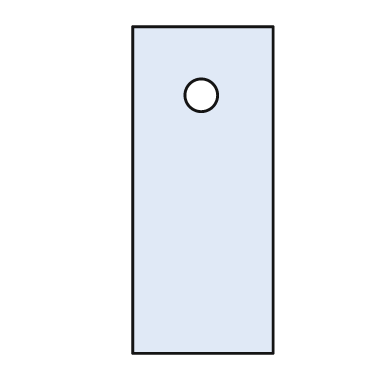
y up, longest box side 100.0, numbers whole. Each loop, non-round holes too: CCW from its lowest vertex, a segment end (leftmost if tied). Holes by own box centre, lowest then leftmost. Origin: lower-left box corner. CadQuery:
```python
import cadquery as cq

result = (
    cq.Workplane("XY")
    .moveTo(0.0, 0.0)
    .lineTo(43.0, 0.0)
    .lineTo(43.0, 100.0)
    .lineTo(0.0, 100.0)
    .close()
    .moveTo(21.0, 79.0)
    .circle(5.0)
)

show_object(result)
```